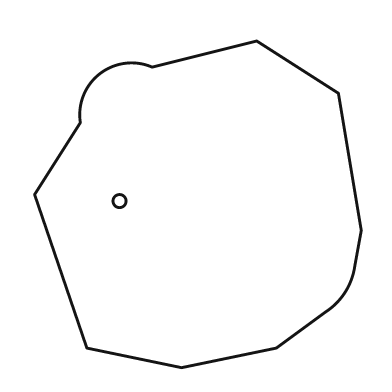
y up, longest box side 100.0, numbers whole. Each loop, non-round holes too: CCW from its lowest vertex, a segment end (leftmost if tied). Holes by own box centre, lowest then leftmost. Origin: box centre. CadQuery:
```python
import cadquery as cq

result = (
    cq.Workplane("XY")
    .moveTo(-5.0, -50.0)
    .lineTo(24.0, -44.0)
    .lineTo(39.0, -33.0)
    .threePointArc((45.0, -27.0), (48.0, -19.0))
    .lineTo(50.0, -8.0)
    .lineTo(43.0, 34.0)
    .lineTo(18.0, 50.0)
    .lineTo(-14.0, 42.0)
    .threePointArc((-30.0, 40.0), (-36.0, 25.0))
    .lineTo(-50.0, 3.0)
    .lineTo(-34.0, -44.0)
    .close()
    .moveTo(-24.0, 1.0)
    .circle(2.0)
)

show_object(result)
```